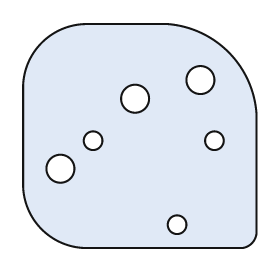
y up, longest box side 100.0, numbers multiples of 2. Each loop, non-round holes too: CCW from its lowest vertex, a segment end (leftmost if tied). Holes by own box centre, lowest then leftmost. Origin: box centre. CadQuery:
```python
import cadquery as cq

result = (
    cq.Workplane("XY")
    .moveTo(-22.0, -48.0)
    .lineTo(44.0, -48.0)
    .threePointArc((48.0, -46.0), (50.0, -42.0))
    .lineTo(50.0, 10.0)
    .threePointArc((38.0, 36.0), (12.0, 48.0))
    .lineTo(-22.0, 48.0)
    .threePointArc((-42.0, 40.0), (-50.0, 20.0))
    .lineTo(-50.0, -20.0)
    .threePointArc((-42.0, -40.0), (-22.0, -48.0))
    .close()
    .moveTo(16.0, -38.0)
    .circle(4.0)
    .moveTo(-34.0, -14.0)
    .circle(6.0)
    .moveTo(-20.0, -2.0)
    .circle(4.0)
    .moveTo(32.0, -2.0)
    .circle(4.0)
    .moveTo(-2.0, 16.0)
    .circle(6.0)
    .moveTo(26.0, 24.0)
    .circle(6.0)
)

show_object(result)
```